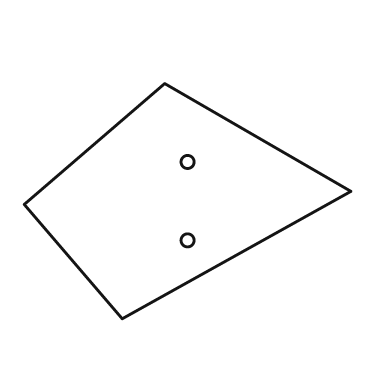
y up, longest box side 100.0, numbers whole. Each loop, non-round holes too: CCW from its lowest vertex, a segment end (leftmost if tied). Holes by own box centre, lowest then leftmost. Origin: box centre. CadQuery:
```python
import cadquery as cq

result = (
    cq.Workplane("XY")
    .moveTo(-20.0, -36.0)
    .lineTo(50.0, 3.0)
    .lineTo(-7.0, 36.0)
    .lineTo(-50.0, -1.0)
    .close()
    .moveTo(0.0, -12.0)
    .circle(2.0)
    .moveTo(0.0, 12.0)
    .circle(2.0)
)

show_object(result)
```